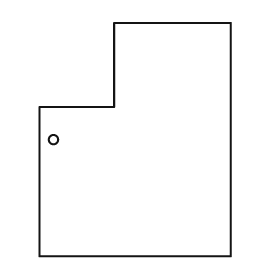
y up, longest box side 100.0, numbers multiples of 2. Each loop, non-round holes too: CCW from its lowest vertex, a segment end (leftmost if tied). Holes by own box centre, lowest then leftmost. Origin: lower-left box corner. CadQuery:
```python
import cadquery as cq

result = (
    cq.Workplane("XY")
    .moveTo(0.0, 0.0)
    .lineTo(82.0, 0.0)
    .lineTo(82.0, 100.0)
    .lineTo(32.0, 100.0)
    .lineTo(32.0, 64.0)
    .lineTo(0.0, 64.0)
    .close()
    .moveTo(6.0, 50.0)
    .circle(2.0)
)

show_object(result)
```